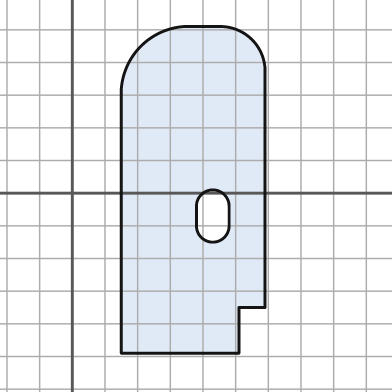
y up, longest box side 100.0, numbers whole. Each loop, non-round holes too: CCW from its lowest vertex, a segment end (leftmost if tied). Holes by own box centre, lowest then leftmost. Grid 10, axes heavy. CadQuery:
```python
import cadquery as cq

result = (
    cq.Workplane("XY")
    .moveTo(15.0, -49.0)
    .lineTo(51.0, -49.0)
    .lineTo(51.0, -35.0)
    .lineTo(59.0, -35.0)
    .lineTo(59.0, 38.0)
    .threePointArc((55.0, 47.0), (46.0, 51.0))
    .lineTo(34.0, 51.0)
    .threePointArc((21.0, 45.0), (15.0, 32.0))
    .close()
    .moveTo(38.0, -10.0)
    .threePointArc((43.0, -15.0), (48.0, -10.0))
    .lineTo(48.0, -4.0)
    .threePointArc((43.0, 1.0), (38.0, -4.0))
    .close()
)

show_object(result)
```